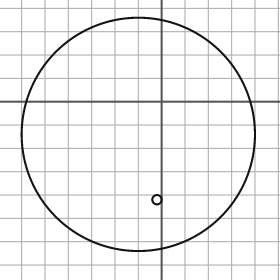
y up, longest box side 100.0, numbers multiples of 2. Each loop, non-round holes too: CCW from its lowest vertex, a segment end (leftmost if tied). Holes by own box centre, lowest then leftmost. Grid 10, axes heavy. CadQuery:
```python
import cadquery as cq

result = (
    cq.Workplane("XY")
    .moveTo(-10.0, -14.0)
    .circle(50.0)
    .moveTo(-2.0, -42.0)
    .circle(2.0)
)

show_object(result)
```